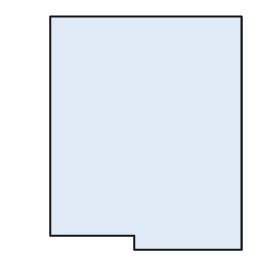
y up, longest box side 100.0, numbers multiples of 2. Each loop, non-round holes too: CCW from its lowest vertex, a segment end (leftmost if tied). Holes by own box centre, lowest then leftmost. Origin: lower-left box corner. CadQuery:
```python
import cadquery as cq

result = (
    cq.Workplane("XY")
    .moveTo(36.0, 0.0)
    .lineTo(82.0, 0.0)
    .lineTo(82.0, 100.0)
    .lineTo(0.0, 100.0)
    .lineTo(0.0, 6.0)
    .lineTo(36.0, 6.0)
    .close()
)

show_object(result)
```